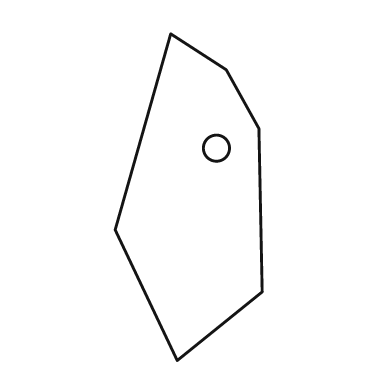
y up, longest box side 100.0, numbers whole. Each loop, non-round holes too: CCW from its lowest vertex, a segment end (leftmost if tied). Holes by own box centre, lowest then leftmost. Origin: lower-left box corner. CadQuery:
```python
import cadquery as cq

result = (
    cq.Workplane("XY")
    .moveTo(19.0, 0.0)
    .lineTo(45.0, 21.0)
    .lineTo(44.0, 71.0)
    .lineTo(34.0, 89.0)
    .lineTo(17.0, 100.0)
    .lineTo(0.0, 40.0)
    .close()
    .moveTo(31.0, 65.0)
    .circle(4.0)
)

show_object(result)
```